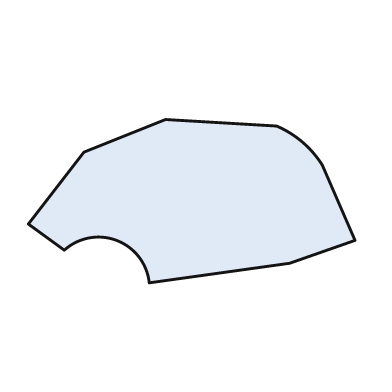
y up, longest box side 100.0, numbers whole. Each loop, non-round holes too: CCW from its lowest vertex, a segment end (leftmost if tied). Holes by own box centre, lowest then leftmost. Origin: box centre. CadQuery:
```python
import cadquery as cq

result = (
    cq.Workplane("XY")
    .moveTo(-13.0, -25.0)
    .lineTo(30.0, -19.0)
    .lineTo(50.0, -12.0)
    .lineTo(40.0, 11.0)
    .threePointArc((34.0, 18.0), (26.0, 23.0))
    .lineTo(-8.0, 25.0)
    .lineTo(-33.0, 15.0)
    .lineTo(-50.0, -7.0)
    .lineTo(-39.0, -15.0)
    .threePointArc((-23.0, -12.0), (-13.0, -25.0))
    .close()
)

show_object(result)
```